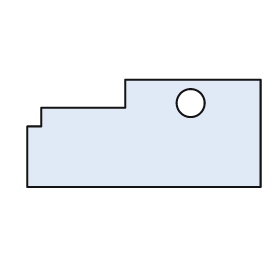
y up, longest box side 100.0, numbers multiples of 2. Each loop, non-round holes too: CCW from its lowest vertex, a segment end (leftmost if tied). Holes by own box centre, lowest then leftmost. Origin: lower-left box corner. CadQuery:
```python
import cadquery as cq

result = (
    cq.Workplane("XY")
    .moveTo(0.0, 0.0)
    .lineTo(100.0, 0.0)
    .lineTo(100.0, 46.0)
    .lineTo(42.0, 46.0)
    .lineTo(42.0, 34.0)
    .lineTo(6.0, 34.0)
    .lineTo(6.0, 26.0)
    .lineTo(0.0, 26.0)
    .close()
    .moveTo(70.0, 36.0)
    .circle(6.0)
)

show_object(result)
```